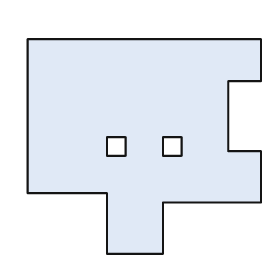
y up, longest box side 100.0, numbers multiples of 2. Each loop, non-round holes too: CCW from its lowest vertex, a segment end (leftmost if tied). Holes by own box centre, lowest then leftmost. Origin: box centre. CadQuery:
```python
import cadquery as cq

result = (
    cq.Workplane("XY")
    .moveTo(-16.0, -46.0)
    .lineTo(8.0, -46.0)
    .lineTo(8.0, -24.0)
    .lineTo(50.0, -24.0)
    .lineTo(50.0, -2.0)
    .lineTo(36.0, -2.0)
    .lineTo(36.0, 28.0)
    .lineTo(50.0, 28.0)
    .lineTo(50.0, 46.0)
    .lineTo(-50.0, 46.0)
    .lineTo(-50.0, -20.0)
    .lineTo(-16.0, -20.0)
    .close()
    .moveTo(-16.0, -4.0)
    .lineTo(-8.0, -4.0)
    .lineTo(-8.0, 4.0)
    .lineTo(-16.0, 4.0)
    .close()
    .moveTo(8.0, -4.0)
    .lineTo(16.0, -4.0)
    .lineTo(16.0, 4.0)
    .lineTo(8.0, 4.0)
    .close()
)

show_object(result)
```